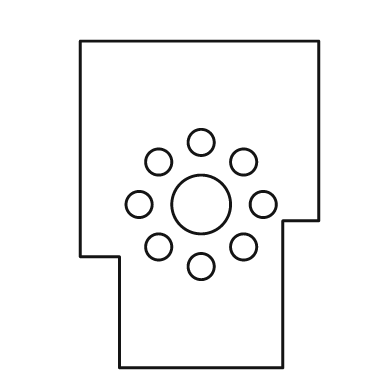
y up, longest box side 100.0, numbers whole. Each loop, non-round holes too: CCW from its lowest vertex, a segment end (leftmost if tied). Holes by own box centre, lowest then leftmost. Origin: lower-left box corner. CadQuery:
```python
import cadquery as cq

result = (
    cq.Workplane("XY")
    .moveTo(12.0, 0.0)
    .lineTo(62.0, 0.0)
    .lineTo(62.0, 45.0)
    .lineTo(73.0, 45.0)
    .lineTo(73.0, 100.0)
    .lineTo(0.0, 100.0)
    .lineTo(0.0, 34.0)
    .lineTo(12.0, 34.0)
    .close()
    .moveTo(37.0, 31.0)
    .circle(4.0)
    .moveTo(24.0, 37.0)
    .circle(4.0)
    .moveTo(50.0, 37.0)
    .circle(4.0)
    .moveTo(18.0, 50.0)
    .circle(4.0)
    .moveTo(37.0, 50.0)
    .circle(9.0)
    .moveTo(56.0, 50.0)
    .circle(4.0)
    .moveTo(24.0, 63.0)
    .circle(4.0)
    .moveTo(50.0, 63.0)
    .circle(4.0)
    .moveTo(37.0, 69.0)
    .circle(4.0)
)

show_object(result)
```